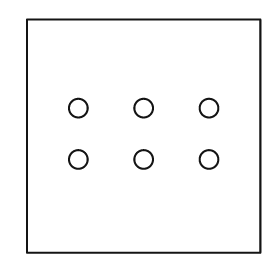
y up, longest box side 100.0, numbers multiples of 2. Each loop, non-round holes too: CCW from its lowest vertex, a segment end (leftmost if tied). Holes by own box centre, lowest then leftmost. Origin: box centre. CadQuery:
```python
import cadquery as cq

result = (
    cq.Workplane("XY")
    .moveTo(-50.0, -50.0)
    .lineTo(50.0, -50.0)
    .lineTo(50.0, 50.0)
    .lineTo(-50.0, 50.0)
    .close()
    .moveTo(-28.0, -10.0)
    .circle(4.0)
    .moveTo(0.0, -10.0)
    .circle(4.0)
    .moveTo(28.0, -10.0)
    .circle(4.0)
    .moveTo(-28.0, 12.0)
    .circle(4.0)
    .moveTo(0.0, 12.0)
    .circle(4.0)
    .moveTo(28.0, 12.0)
    .circle(4.0)
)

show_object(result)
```